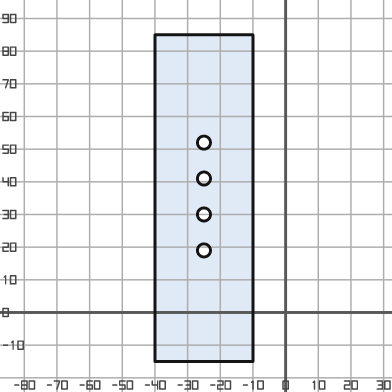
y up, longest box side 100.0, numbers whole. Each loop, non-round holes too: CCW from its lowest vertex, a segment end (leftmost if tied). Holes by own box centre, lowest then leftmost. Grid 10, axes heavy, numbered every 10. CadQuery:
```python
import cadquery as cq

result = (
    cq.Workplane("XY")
    .moveTo(-40.0, -15.0)
    .lineTo(-10.0, -15.0)
    .lineTo(-10.0, 85.0)
    .lineTo(-40.0, 85.0)
    .close()
    .moveTo(-25.0, 19.0)
    .circle(2.0)
    .moveTo(-25.0, 30.0)
    .circle(2.0)
    .moveTo(-25.0, 41.0)
    .circle(2.0)
    .moveTo(-25.0, 52.0)
    .circle(2.0)
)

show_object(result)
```